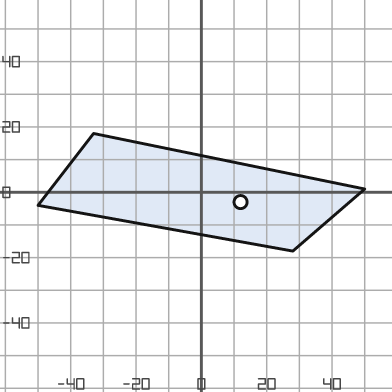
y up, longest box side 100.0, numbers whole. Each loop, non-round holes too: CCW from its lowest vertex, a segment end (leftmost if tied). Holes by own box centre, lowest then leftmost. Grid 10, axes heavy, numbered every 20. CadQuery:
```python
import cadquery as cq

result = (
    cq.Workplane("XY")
    .moveTo(28.0, -18.0)
    .lineTo(50.0, 1.0)
    .lineTo(-33.0, 18.0)
    .lineTo(-50.0, -4.0)
    .close()
    .moveTo(12.0, -3.0)
    .circle(2.0)
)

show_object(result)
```